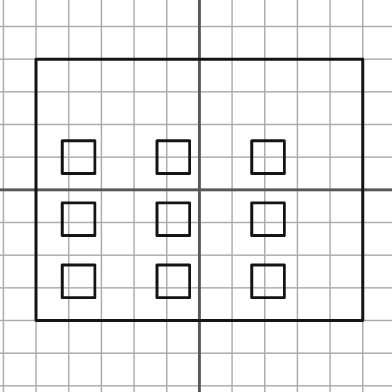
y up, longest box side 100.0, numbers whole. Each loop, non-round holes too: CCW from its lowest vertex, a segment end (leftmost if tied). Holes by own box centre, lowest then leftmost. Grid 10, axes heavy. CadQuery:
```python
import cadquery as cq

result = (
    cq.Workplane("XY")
    .moveTo(-50.0, -40.0)
    .lineTo(50.0, -40.0)
    .lineTo(50.0, 40.0)
    .lineTo(-50.0, 40.0)
    .close()
    .moveTo(-42.0, -33.0)
    .lineTo(-32.0, -33.0)
    .lineTo(-32.0, -23.0)
    .lineTo(-42.0, -23.0)
    .close()
    .moveTo(-13.0, -33.0)
    .lineTo(-3.0, -33.0)
    .lineTo(-3.0, -23.0)
    .lineTo(-13.0, -23.0)
    .close()
    .moveTo(16.0, -33.0)
    .lineTo(26.0, -33.0)
    .lineTo(26.0, -23.0)
    .lineTo(16.0, -23.0)
    .close()
    .moveTo(-42.0, -14.0)
    .lineTo(-32.0, -14.0)
    .lineTo(-32.0, -4.0)
    .lineTo(-42.0, -4.0)
    .close()
    .moveTo(-13.0, -14.0)
    .lineTo(-3.0, -14.0)
    .lineTo(-3.0, -4.0)
    .lineTo(-13.0, -4.0)
    .close()
    .moveTo(16.0, -14.0)
    .lineTo(26.0, -14.0)
    .lineTo(26.0, -4.0)
    .lineTo(16.0, -4.0)
    .close()
    .moveTo(-42.0, 5.0)
    .lineTo(-32.0, 5.0)
    .lineTo(-32.0, 15.0)
    .lineTo(-42.0, 15.0)
    .close()
    .moveTo(-13.0, 5.0)
    .lineTo(-3.0, 5.0)
    .lineTo(-3.0, 15.0)
    .lineTo(-13.0, 15.0)
    .close()
    .moveTo(16.0, 5.0)
    .lineTo(26.0, 5.0)
    .lineTo(26.0, 15.0)
    .lineTo(16.0, 15.0)
    .close()
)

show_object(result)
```